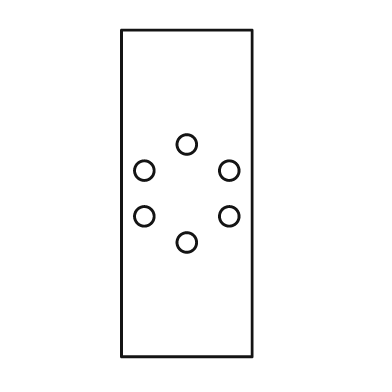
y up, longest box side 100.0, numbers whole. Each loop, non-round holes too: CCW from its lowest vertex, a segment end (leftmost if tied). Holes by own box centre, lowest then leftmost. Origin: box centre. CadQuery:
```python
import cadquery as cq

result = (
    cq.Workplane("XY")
    .moveTo(-20.0, -50.0)
    .lineTo(20.0, -50.0)
    .lineTo(20.0, 50.0)
    .lineTo(-20.0, 50.0)
    .close()
    .moveTo(0.0, -15.0)
    .circle(3.0)
    .moveTo(-13.0, -7.0)
    .circle(3.0)
    .moveTo(13.0, -7.0)
    .circle(3.0)
    .moveTo(-13.0, 7.0)
    .circle(3.0)
    .moveTo(13.0, 7.0)
    .circle(3.0)
    .moveTo(0.0, 15.0)
    .circle(3.0)
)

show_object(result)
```